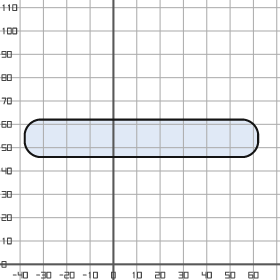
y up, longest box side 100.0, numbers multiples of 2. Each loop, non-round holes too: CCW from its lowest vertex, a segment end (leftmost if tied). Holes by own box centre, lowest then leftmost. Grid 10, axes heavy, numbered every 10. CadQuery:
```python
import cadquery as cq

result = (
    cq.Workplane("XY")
    .moveTo(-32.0, 46.0)
    .lineTo(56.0, 46.0)
    .threePointArc((60.0, 48.0), (62.0, 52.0))
    .lineTo(62.0, 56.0)
    .threePointArc((60.0, 60.0), (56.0, 62.0))
    .lineTo(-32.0, 62.0)
    .threePointArc((-36.0, 60.0), (-38.0, 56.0))
    .lineTo(-38.0, 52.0)
    .threePointArc((-36.0, 48.0), (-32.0, 46.0))
    .close()
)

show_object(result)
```